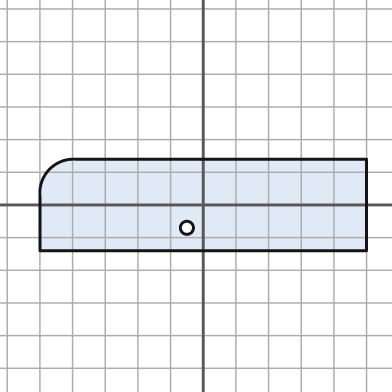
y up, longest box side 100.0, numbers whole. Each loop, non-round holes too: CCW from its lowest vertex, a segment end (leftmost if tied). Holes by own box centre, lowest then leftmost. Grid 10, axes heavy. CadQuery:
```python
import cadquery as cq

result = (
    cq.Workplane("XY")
    .moveTo(-50.0, -14.0)
    .lineTo(50.0, -14.0)
    .lineTo(50.0, 14.0)
    .lineTo(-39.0, 14.0)
    .threePointArc((-47.0, 11.0), (-50.0, 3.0))
    .close()
    .moveTo(-5.0, -7.0)
    .circle(2.0)
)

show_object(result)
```